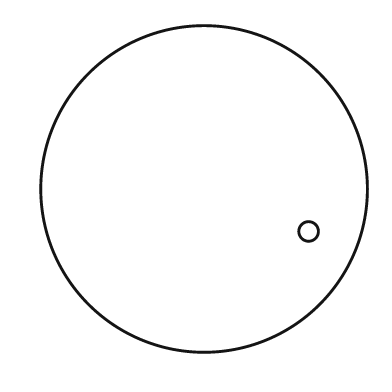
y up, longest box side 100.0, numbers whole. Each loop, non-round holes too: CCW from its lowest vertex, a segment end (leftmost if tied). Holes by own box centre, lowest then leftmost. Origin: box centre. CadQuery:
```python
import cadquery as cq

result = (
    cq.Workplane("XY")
    .moveTo(0.0, 0.0)
    .circle(50.0)
    .moveTo(32.0, -13.0)
    .circle(3.0)
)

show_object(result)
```